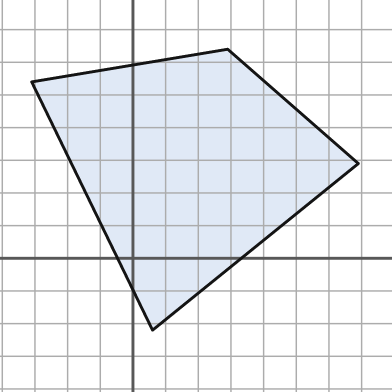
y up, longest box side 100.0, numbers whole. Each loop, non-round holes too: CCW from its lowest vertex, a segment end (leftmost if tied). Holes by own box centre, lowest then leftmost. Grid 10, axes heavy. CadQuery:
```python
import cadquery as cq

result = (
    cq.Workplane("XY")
    .moveTo(6.0, -22.0)
    .lineTo(69.0, 29.0)
    .lineTo(29.0, 64.0)
    .lineTo(-31.0, 54.0)
    .close()
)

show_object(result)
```